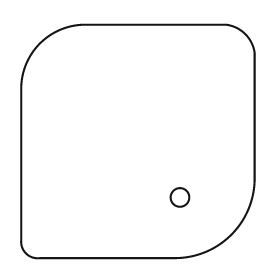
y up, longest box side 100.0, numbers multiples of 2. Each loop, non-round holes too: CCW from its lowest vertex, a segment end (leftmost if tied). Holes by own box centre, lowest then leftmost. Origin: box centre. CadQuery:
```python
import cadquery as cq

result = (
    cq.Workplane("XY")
    .moveTo(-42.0, -50.0)
    .lineTo(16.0, -50.0)
    .threePointArc((40.0, -40.0), (50.0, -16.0))
    .lineTo(50.0, 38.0)
    .threePointArc((46.0, 46.0), (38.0, 50.0))
    .lineTo(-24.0, 50.0)
    .threePointArc((-42.0, 42.0), (-50.0, 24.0))
    .lineTo(-50.0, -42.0)
    .threePointArc((-48.0, -48.0), (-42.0, -50.0))
    .close()
    .moveTo(18.0, -24.0)
    .circle(4.0)
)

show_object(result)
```